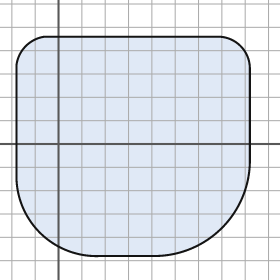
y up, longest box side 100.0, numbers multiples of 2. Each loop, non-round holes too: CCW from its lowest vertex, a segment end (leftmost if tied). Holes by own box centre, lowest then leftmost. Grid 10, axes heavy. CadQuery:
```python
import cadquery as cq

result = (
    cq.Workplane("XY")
    .moveTo(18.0, -48.0)
    .lineTo(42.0, -48.0)
    .threePointArc((70.0, -36.0), (82.0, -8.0))
    .lineTo(82.0, 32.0)
    .threePointArc((78.0, 42.0), (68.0, 46.0))
    .lineTo(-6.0, 46.0)
    .threePointArc((-14.0, 42.0), (-18.0, 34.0))
    .lineTo(-18.0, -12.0)
    .threePointArc((-8.0, -38.0), (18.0, -48.0))
    .close()
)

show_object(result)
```